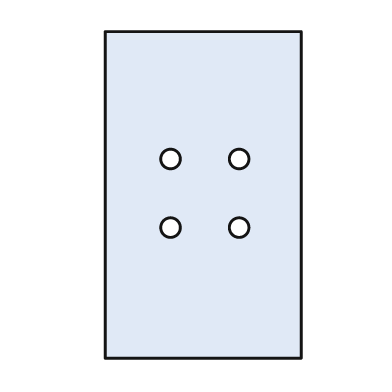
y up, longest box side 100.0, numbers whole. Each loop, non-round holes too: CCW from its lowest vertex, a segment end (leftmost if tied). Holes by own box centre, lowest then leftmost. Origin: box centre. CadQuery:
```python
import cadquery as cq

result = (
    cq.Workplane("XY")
    .moveTo(-30.0, -50.0)
    .lineTo(30.0, -50.0)
    .lineTo(30.0, 50.0)
    .lineTo(-30.0, 50.0)
    .close()
    .moveTo(-10.0, -10.0)
    .circle(3.0)
    .moveTo(11.0, -10.0)
    .circle(3.0)
    .moveTo(-10.0, 11.0)
    .circle(3.0)
    .moveTo(11.0, 11.0)
    .circle(3.0)
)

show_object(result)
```